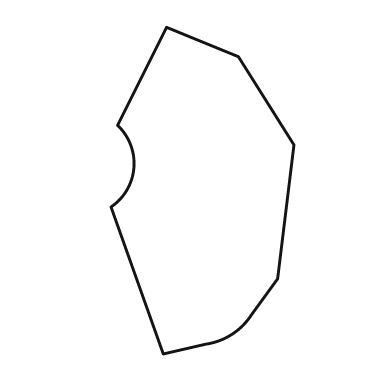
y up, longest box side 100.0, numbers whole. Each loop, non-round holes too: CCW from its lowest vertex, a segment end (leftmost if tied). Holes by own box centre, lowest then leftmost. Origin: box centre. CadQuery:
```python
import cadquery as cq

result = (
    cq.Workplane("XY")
    .moveTo(-12.0, -50.0)
    .lineTo(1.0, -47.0)
    .threePointArc((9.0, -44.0), (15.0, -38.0))
    .lineTo(23.0, -27.0)
    .lineTo(28.0, 14.0)
    .lineTo(11.0, 41.0)
    .lineTo(-11.0, 50.0)
    .lineTo(-26.0, 20.0)
    .threePointArc((-21.0, 7.0), (-28.0, -5.0))
    .close()
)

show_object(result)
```